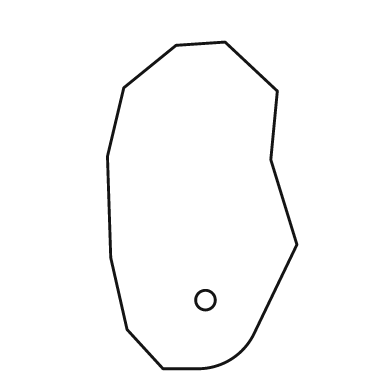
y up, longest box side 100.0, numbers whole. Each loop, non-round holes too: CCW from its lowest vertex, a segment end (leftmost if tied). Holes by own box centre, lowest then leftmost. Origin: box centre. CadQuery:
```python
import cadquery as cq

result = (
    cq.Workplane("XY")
    .moveTo(-12.0, -50.0)
    .lineTo(-1.0, -50.0)
    .threePointArc((9.0, -47.0), (16.0, -39.0))
    .lineTo(29.0, -12.0)
    .lineTo(21.0, 14.0)
    .lineTo(23.0, 35.0)
    .lineTo(7.0, 50.0)
    .lineTo(-8.0, 49.0)
    .lineTo(-24.0, 36.0)
    .lineTo(-29.0, 15.0)
    .lineTo(-28.0, -16.0)
    .lineTo(-23.0, -38.0)
    .close()
    .moveTo(1.0, -29.0)
    .circle(3.0)
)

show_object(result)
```